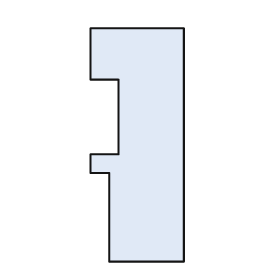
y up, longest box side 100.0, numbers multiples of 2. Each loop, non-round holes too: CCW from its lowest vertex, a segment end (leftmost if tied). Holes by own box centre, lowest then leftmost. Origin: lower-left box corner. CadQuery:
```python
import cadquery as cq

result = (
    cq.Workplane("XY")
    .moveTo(8.0, 0.0)
    .lineTo(40.0, 0.0)
    .lineTo(40.0, 100.0)
    .lineTo(0.0, 100.0)
    .lineTo(0.0, 78.0)
    .lineTo(12.0, 78.0)
    .lineTo(12.0, 46.0)
    .lineTo(0.0, 46.0)
    .lineTo(0.0, 38.0)
    .lineTo(8.0, 38.0)
    .close()
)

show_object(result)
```